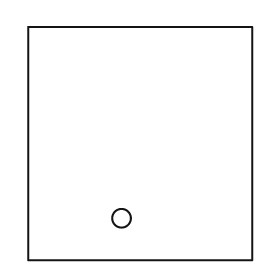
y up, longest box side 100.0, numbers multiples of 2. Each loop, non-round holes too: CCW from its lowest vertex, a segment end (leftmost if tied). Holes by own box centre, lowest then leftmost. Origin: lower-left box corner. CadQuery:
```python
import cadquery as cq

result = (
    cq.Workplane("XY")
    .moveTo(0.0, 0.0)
    .lineTo(96.0, 0.0)
    .lineTo(96.0, 100.0)
    .lineTo(0.0, 100.0)
    .close()
    .moveTo(40.0, 18.0)
    .circle(4.0)
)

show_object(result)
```